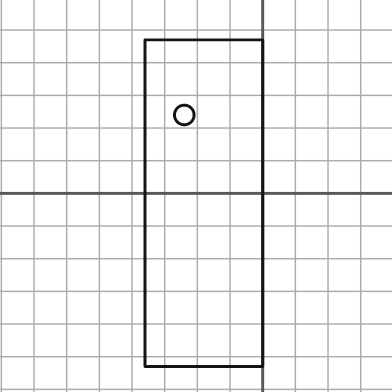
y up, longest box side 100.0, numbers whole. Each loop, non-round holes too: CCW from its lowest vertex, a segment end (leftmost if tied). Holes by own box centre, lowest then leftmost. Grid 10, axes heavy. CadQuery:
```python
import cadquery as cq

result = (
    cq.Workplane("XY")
    .moveTo(-36.0, -53.0)
    .lineTo(0.0, -53.0)
    .lineTo(0.0, 47.0)
    .lineTo(-36.0, 47.0)
    .close()
    .moveTo(-24.0, 24.0)
    .circle(3.0)
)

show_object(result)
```